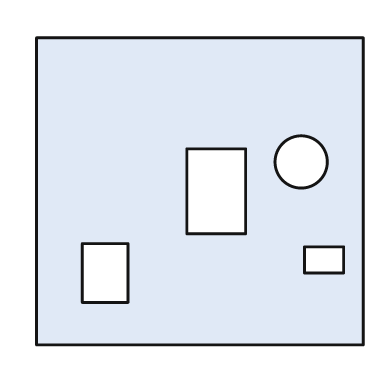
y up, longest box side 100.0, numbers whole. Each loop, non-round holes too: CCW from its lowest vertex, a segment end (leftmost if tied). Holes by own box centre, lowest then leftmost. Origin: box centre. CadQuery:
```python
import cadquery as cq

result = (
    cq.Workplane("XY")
    .moveTo(-50.0, -47.0)
    .lineTo(50.0, -47.0)
    .lineTo(50.0, 47.0)
    .lineTo(-50.0, 47.0)
    .close()
    .moveTo(-36.0, -34.0)
    .lineTo(-22.0, -34.0)
    .lineTo(-22.0, -16.0)
    .lineTo(-36.0, -16.0)
    .close()
    .moveTo(32.0, -25.0)
    .lineTo(44.0, -25.0)
    .lineTo(44.0, -17.0)
    .lineTo(32.0, -17.0)
    .close()
    .moveTo(-4.0, -13.0)
    .lineTo(14.0, -13.0)
    .lineTo(14.0, 13.0)
    .lineTo(-4.0, 13.0)
    .close()
    .moveTo(31.0, 9.0)
    .circle(8.0)
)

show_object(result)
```